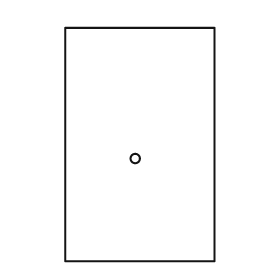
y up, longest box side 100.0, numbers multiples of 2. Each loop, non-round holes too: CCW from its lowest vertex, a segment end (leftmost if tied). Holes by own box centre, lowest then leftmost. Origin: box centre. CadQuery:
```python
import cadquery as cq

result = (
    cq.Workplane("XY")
    .moveTo(-32.0, -50.0)
    .lineTo(32.0, -50.0)
    .lineTo(32.0, 50.0)
    .lineTo(-32.0, 50.0)
    .close()
    .moveTo(-2.0, -6.0)
    .circle(2.0)
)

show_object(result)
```